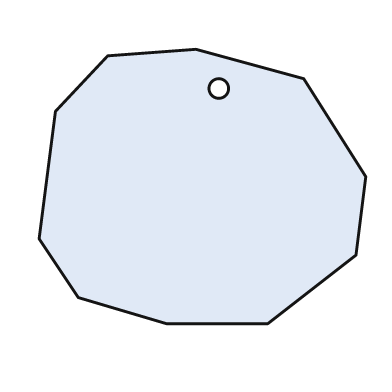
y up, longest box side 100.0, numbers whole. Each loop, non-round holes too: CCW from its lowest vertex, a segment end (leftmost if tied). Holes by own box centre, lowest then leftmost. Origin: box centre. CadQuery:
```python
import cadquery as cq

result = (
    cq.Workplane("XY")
    .moveTo(-11.0, -42.0)
    .lineTo(20.0, -42.0)
    .lineTo(47.0, -21.0)
    .lineTo(50.0, 3.0)
    .lineTo(31.0, 33.0)
    .lineTo(-2.0, 42.0)
    .lineTo(-29.0, 40.0)
    .lineTo(-45.0, 23.0)
    .lineTo(-50.0, -16.0)
    .lineTo(-38.0, -34.0)
    .close()
    .moveTo(5.0, 30.0)
    .circle(3.0)
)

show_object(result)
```